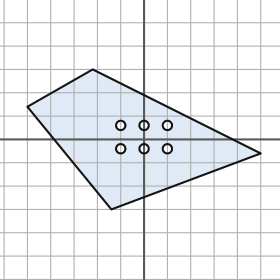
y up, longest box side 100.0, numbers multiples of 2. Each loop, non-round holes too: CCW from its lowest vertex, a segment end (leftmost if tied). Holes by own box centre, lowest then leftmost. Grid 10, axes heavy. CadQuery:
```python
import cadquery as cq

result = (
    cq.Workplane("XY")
    .moveTo(-14.0, -30.0)
    .lineTo(50.0, -6.0)
    .lineTo(-22.0, 30.0)
    .lineTo(-50.0, 14.0)
    .close()
    .moveTo(-10.0, -4.0)
    .circle(2.0)
    .moveTo(0.0, -4.0)
    .circle(2.0)
    .moveTo(10.0, -4.0)
    .circle(2.0)
    .moveTo(-10.0, 6.0)
    .circle(2.0)
    .moveTo(0.0, 6.0)
    .circle(2.0)
    .moveTo(10.0, 6.0)
    .circle(2.0)
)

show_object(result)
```